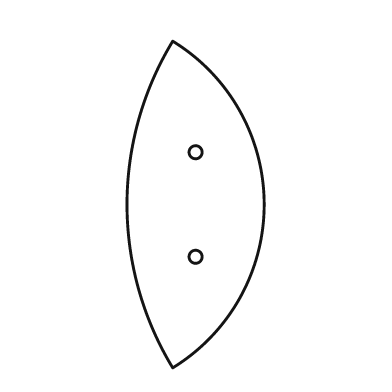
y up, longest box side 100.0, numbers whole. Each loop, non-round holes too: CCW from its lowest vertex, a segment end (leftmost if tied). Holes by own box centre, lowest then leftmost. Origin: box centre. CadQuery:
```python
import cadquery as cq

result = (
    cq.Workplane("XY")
    .moveTo(-7.0, -50.0)
    .threePointArc((21.0, 0.0), (-7.0, 50.0))
    .threePointArc((-21.0, 0.0), (-7.0, -50.0))
    .close()
    .moveTo(0.0, -16.0)
    .circle(2.0)
    .moveTo(0.0, 16.0)
    .circle(2.0)
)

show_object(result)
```